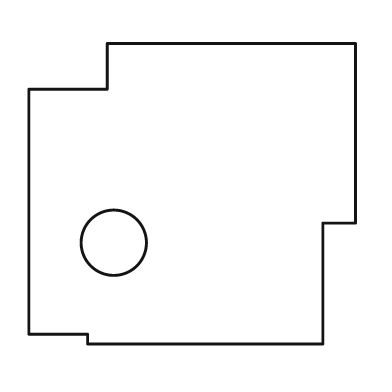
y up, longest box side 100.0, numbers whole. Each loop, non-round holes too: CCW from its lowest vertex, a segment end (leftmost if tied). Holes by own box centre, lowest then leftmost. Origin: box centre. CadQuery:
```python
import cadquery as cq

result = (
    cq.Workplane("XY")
    .moveTo(-32.0, -46.0)
    .lineTo(40.0, -46.0)
    .lineTo(40.0, -9.0)
    .lineTo(50.0, -9.0)
    .lineTo(50.0, 46.0)
    .lineTo(-26.0, 46.0)
    .lineTo(-26.0, 32.0)
    .lineTo(-50.0, 32.0)
    .lineTo(-50.0, -43.0)
    .lineTo(-32.0, -43.0)
    .close()
    .moveTo(-24.0, -15.0)
    .circle(10.0)
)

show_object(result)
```